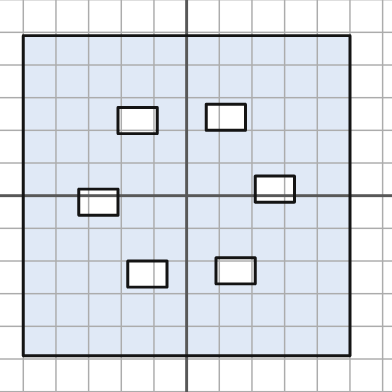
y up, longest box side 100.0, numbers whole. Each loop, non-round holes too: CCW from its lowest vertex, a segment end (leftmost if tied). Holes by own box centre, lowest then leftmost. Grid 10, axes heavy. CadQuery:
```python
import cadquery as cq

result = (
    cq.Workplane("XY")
    .moveTo(-50.0, -49.0)
    .lineTo(50.0, -49.0)
    .lineTo(50.0, 49.0)
    .lineTo(-50.0, 49.0)
    .close()
    .moveTo(-18.0, -28.0)
    .lineTo(-6.0, -28.0)
    .lineTo(-6.0, -20.0)
    .lineTo(-18.0, -20.0)
    .close()
    .moveTo(9.0, -27.0)
    .lineTo(21.0, -27.0)
    .lineTo(21.0, -19.0)
    .lineTo(9.0, -19.0)
    .close()
    .moveTo(-33.0, -6.0)
    .lineTo(-21.0, -6.0)
    .lineTo(-21.0, 2.0)
    .lineTo(-33.0, 2.0)
    .close()
    .moveTo(21.0, -2.0)
    .lineTo(33.0, -2.0)
    .lineTo(33.0, 6.0)
    .lineTo(21.0, 6.0)
    .close()
    .moveTo(-21.0, 19.0)
    .lineTo(-9.0, 19.0)
    .lineTo(-9.0, 27.0)
    .lineTo(-21.0, 27.0)
    .close()
    .moveTo(6.0, 20.0)
    .lineTo(18.0, 20.0)
    .lineTo(18.0, 28.0)
    .lineTo(6.0, 28.0)
    .close()
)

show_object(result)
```